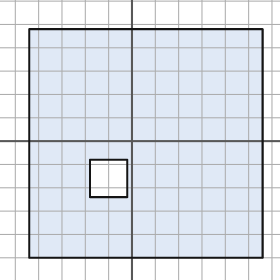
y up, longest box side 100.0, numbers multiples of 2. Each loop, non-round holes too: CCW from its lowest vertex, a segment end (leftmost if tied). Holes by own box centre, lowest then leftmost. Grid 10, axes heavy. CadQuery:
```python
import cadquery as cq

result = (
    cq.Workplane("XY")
    .moveTo(-44.0, -50.0)
    .lineTo(56.0, -50.0)
    .lineTo(56.0, 48.0)
    .lineTo(-44.0, 48.0)
    .close()
    .moveTo(-18.0, -24.0)
    .lineTo(-2.0, -24.0)
    .lineTo(-2.0, -8.0)
    .lineTo(-18.0, -8.0)
    .close()
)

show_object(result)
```